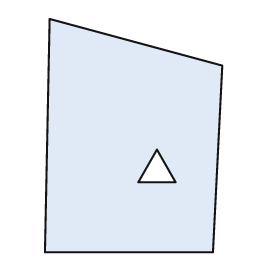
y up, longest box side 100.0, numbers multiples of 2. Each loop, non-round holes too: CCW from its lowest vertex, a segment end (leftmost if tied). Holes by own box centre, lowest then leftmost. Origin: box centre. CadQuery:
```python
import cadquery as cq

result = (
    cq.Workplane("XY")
    .moveTo(-38.0, -50.0)
    .lineTo(34.0, -50.0)
    .lineTo(38.0, 30.0)
    .lineTo(-36.0, 50.0)
    .close()
    .moveTo(2.0, -20.0)
    .lineTo(18.0, -20.0)
    .lineTo(10.0, -6.0)
    .close()
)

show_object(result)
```